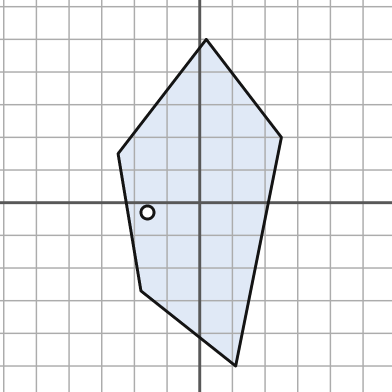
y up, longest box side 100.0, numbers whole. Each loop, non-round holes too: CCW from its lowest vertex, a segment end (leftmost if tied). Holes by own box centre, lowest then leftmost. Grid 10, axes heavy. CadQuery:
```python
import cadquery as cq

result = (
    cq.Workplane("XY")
    .moveTo(11.0, -50.0)
    .lineTo(25.0, 20.0)
    .lineTo(2.0, 50.0)
    .lineTo(-25.0, 15.0)
    .lineTo(-18.0, -27.0)
    .close()
    .moveTo(-16.0, -3.0)
    .circle(2.0)
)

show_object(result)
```